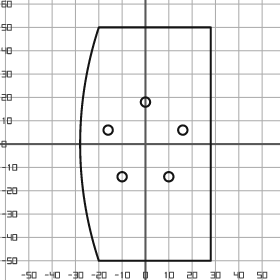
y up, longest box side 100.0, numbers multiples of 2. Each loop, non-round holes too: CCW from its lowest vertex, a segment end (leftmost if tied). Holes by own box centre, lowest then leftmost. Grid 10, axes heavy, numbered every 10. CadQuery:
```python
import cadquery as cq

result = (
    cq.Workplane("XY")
    .moveTo(-20.0, -50.0)
    .lineTo(28.0, -50.0)
    .lineTo(28.0, 50.0)
    .lineTo(-20.0, 50.0)
    .threePointArc((-28.0, 0.0), (-20.0, -50.0))
    .close()
    .moveTo(-10.0, -14.0)
    .circle(2.0)
    .moveTo(10.0, -14.0)
    .circle(2.0)
    .moveTo(-16.0, 6.0)
    .circle(2.0)
    .moveTo(16.0, 6.0)
    .circle(2.0)
    .moveTo(0.0, 18.0)
    .circle(2.0)
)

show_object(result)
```